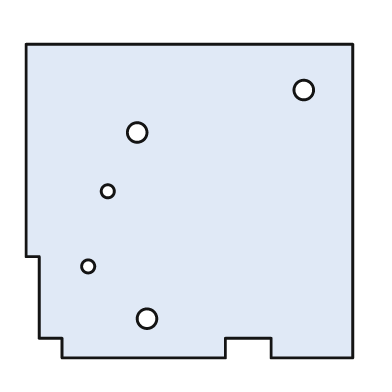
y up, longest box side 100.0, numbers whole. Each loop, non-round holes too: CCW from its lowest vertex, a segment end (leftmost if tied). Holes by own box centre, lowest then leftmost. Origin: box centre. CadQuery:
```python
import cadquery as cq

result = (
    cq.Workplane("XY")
    .moveTo(-39.0, -48.0)
    .lineTo(11.0, -48.0)
    .lineTo(11.0, -42.0)
    .lineTo(25.0, -42.0)
    .lineTo(25.0, -48.0)
    .lineTo(50.0, -48.0)
    .lineTo(50.0, 48.0)
    .lineTo(-50.0, 48.0)
    .lineTo(-50.0, -17.0)
    .lineTo(-46.0, -17.0)
    .lineTo(-46.0, -42.0)
    .lineTo(-39.0, -42.0)
    .close()
    .moveTo(-13.0, -36.0)
    .circle(3.0)
    .moveTo(-31.0, -20.0)
    .circle(2.0)
    .moveTo(-25.0, 3.0)
    .circle(2.0)
    .moveTo(-16.0, 21.0)
    .circle(3.0)
    .moveTo(35.0, 34.0)
    .circle(3.0)
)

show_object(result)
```